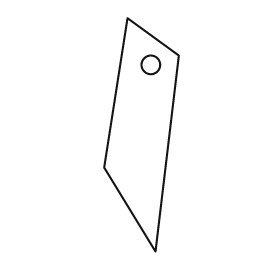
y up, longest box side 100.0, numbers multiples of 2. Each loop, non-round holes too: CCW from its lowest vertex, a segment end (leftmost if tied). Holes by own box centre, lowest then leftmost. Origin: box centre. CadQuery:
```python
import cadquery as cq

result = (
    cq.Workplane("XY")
    .moveTo(6.0, -50.0)
    .lineTo(16.0, 34.0)
    .lineTo(-6.0, 50.0)
    .lineTo(-16.0, -14.0)
    .close()
    .moveTo(4.0, 30.0)
    .circle(4.0)
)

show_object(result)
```